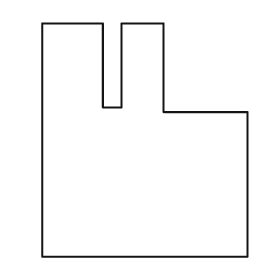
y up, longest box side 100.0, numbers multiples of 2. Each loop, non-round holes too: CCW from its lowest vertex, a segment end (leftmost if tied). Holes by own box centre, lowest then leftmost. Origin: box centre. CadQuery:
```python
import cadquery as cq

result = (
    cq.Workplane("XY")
    .moveTo(-44.0, -50.0)
    .lineTo(44.0, -50.0)
    .lineTo(44.0, 12.0)
    .lineTo(8.0, 12.0)
    .lineTo(8.0, 50.0)
    .lineTo(-10.0, 50.0)
    .lineTo(-10.0, 14.0)
    .lineTo(-18.0, 14.0)
    .lineTo(-18.0, 50.0)
    .lineTo(-44.0, 50.0)
    .close()
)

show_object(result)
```